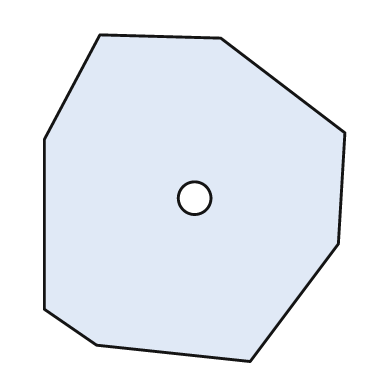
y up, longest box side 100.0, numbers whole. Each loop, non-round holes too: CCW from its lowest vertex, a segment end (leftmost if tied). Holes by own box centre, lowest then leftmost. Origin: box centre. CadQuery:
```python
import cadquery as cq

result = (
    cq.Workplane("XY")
    .moveTo(17.0, -50.0)
    .lineTo(44.0, -14.0)
    .lineTo(46.0, 20.0)
    .lineTo(8.0, 49.0)
    .lineTo(-29.0, 50.0)
    .lineTo(-46.0, 18.0)
    .lineTo(-46.0, -34.0)
    .lineTo(-30.0, -45.0)
    .close()
    .moveTo(0.0, 0.0)
    .circle(5.0)
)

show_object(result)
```